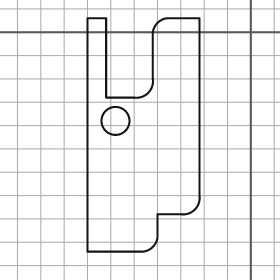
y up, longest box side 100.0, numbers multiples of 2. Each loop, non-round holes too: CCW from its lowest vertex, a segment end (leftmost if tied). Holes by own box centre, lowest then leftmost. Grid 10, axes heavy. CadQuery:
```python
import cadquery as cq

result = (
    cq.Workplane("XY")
    .moveTo(-70.0, -94.0)
    .lineTo(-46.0, -94.0)
    .threePointArc((-42.0, -92.0), (-40.0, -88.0))
    .lineTo(-40.0, -78.0)
    .lineTo(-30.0, -78.0)
    .threePointArc((-24.0, -76.0), (-22.0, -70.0))
    .lineTo(-22.0, 6.0)
    .lineTo(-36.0, 6.0)
    .threePointArc((-40.0, 4.0), (-42.0, 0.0))
    .lineTo(-42.0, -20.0)
    .threePointArc((-44.0, -26.0), (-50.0, -28.0))
    .lineTo(-62.0, -28.0)
    .lineTo(-62.0, 6.0)
    .lineTo(-70.0, 6.0)
    .close()
    .moveTo(-58.0, -38.0)
    .circle(6.0)
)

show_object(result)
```